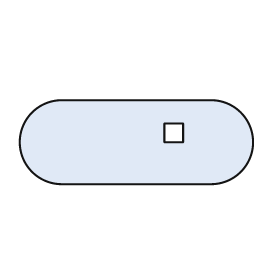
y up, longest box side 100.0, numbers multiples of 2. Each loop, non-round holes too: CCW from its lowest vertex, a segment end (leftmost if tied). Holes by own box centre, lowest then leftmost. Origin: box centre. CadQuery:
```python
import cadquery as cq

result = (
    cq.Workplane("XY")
    .moveTo(-32.0, -18.0)
    .lineTo(32.0, -18.0)
    .threePointArc((50.0, 0.0), (32.0, 18.0))
    .lineTo(-32.0, 18.0)
    .threePointArc((-50.0, 0.0), (-32.0, -18.0))
    .close()
    .moveTo(12.0, 0.0)
    .lineTo(20.0, 0.0)
    .lineTo(20.0, 8.0)
    .lineTo(12.0, 8.0)
    .close()
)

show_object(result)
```